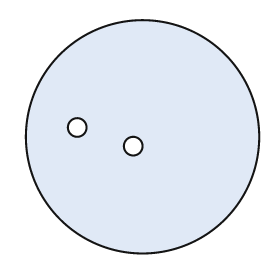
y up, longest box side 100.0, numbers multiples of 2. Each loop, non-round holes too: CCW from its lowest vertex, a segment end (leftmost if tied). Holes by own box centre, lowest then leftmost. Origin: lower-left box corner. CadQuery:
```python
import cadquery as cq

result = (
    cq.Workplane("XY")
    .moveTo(50.0, 50.0)
    .circle(50.0)
    .moveTo(46.0, 46.0)
    .circle(4.0)
    .moveTo(22.0, 54.0)
    .circle(4.0)
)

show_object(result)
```